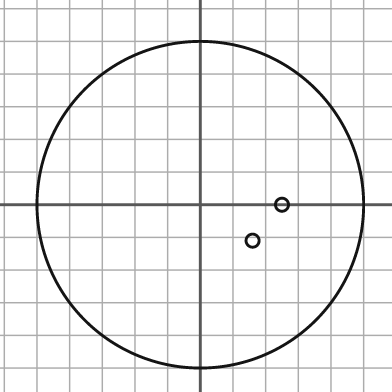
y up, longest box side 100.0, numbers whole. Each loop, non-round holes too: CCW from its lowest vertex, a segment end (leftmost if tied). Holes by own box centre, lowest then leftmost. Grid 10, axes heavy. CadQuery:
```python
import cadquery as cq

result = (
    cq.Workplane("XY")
    .moveTo(0.0, 0.0)
    .circle(50.0)
    .moveTo(16.0, -11.0)
    .circle(2.0)
    .moveTo(25.0, 0.0)
    .circle(2.0)
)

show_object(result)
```